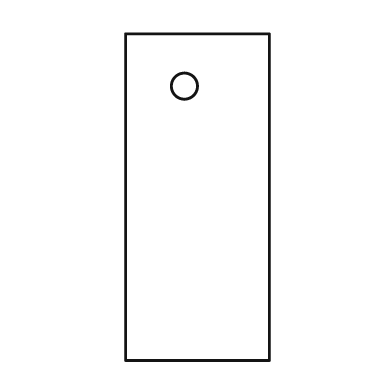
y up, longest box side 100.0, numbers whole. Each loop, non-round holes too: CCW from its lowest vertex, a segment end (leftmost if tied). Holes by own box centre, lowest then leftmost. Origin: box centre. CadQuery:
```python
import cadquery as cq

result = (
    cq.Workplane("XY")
    .moveTo(-22.0, -50.0)
    .lineTo(22.0, -50.0)
    .lineTo(22.0, 50.0)
    .lineTo(-22.0, 50.0)
    .close()
    .moveTo(-4.0, 34.0)
    .circle(4.0)
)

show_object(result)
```